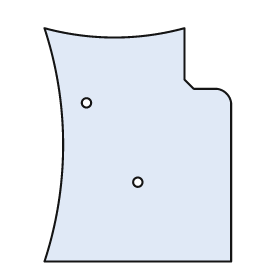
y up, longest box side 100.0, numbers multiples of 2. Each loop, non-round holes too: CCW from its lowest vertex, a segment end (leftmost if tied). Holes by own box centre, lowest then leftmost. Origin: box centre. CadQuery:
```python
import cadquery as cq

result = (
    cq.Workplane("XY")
    .moveTo(-40.0, -50.0)
    .lineTo(40.0, -50.0)
    .lineTo(40.0, 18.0)
    .threePointArc((38.0, 22.0), (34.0, 24.0))
    .lineTo(24.0, 24.0)
    .lineTo(20.0, 28.0)
    .lineTo(20.0, 50.0)
    .threePointArc((-10.0, 46.0), (-40.0, 50.0))
    .threePointArc((-32.0, 0.0), (-40.0, -50.0))
    .close()
    .moveTo(0.0, -16.0)
    .circle(2.0)
    .moveTo(-22.0, 18.0)
    .circle(2.0)
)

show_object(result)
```